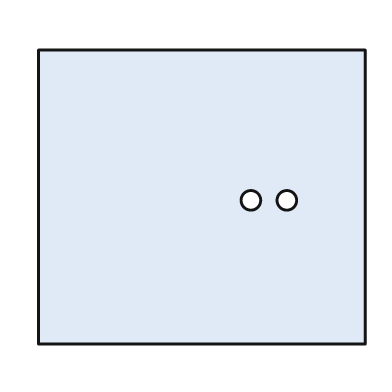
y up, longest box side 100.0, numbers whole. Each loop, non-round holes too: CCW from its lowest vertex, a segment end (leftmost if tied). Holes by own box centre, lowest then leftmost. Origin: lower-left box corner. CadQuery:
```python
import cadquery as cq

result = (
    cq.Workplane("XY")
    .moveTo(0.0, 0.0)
    .lineTo(100.0, 0.0)
    .lineTo(100.0, 90.0)
    .lineTo(0.0, 90.0)
    .close()
    .moveTo(65.0, 44.0)
    .circle(3.0)
    .moveTo(76.0, 44.0)
    .circle(3.0)
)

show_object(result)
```